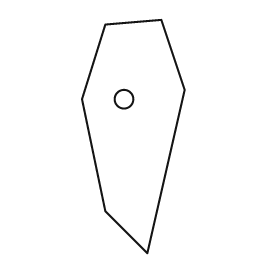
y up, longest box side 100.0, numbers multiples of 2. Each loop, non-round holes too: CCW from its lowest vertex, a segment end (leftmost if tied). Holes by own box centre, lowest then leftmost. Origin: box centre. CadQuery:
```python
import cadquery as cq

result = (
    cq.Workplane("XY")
    .moveTo(6.0, -50.0)
    .lineTo(22.0, 20.0)
    .lineTo(12.0, 50.0)
    .lineTo(-12.0, 48.0)
    .lineTo(-22.0, 16.0)
    .lineTo(-12.0, -32.0)
    .close()
    .moveTo(-4.0, 16.0)
    .circle(4.0)
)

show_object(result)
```